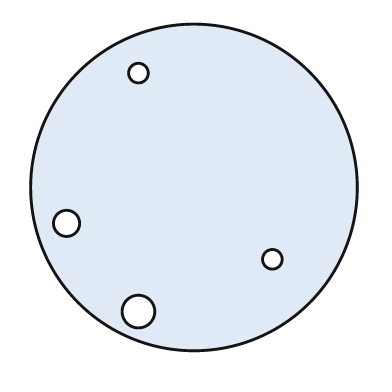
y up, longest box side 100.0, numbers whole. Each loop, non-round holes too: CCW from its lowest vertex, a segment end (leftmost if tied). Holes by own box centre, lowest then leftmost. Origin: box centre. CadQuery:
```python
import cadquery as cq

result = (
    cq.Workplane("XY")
    .moveTo(0.0, 0.0)
    .circle(50.0)
    .moveTo(-17.0, -38.0)
    .circle(5.0)
    .moveTo(24.0, -22.0)
    .circle(3.0)
    .moveTo(-39.0, -11.0)
    .circle(4.0)
    .moveTo(-17.0, 35.0)
    .circle(3.0)
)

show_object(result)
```